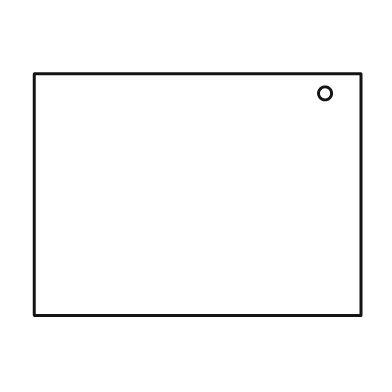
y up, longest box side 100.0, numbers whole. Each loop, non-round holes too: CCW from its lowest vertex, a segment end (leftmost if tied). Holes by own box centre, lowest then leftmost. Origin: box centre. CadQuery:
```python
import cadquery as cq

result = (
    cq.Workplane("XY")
    .moveTo(-50.0, -37.0)
    .lineTo(50.0, -37.0)
    .lineTo(50.0, 37.0)
    .lineTo(-50.0, 37.0)
    .close()
    .moveTo(39.0, 31.0)
    .circle(2.0)
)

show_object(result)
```